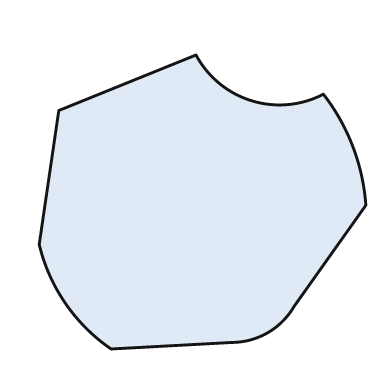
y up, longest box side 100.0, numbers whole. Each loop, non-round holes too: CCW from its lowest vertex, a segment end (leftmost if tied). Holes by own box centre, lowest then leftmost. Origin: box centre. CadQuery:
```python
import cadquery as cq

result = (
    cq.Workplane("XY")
    .moveTo(-28.0, -45.0)
    .lineTo(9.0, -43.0)
    .threePointArc((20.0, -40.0), (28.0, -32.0))
    .lineTo(50.0, -1.0)
    .threePointArc((46.0, 17.0), (37.0, 33.0))
    .threePointArc((15.0, 31.0), (-2.0, 45.0))
    .lineTo(-44.0, 28.0)
    .lineTo(-50.0, -13.0)
    .threePointArc((-42.0, -31.0), (-28.0, -45.0))
    .close()
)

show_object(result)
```